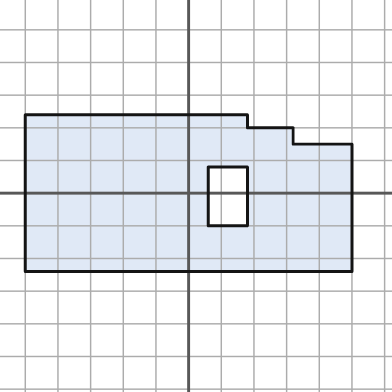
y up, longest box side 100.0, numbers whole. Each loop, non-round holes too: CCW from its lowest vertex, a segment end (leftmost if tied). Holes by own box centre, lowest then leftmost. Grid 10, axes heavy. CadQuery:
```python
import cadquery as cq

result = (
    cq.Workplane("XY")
    .moveTo(-50.0, -24.0)
    .lineTo(50.0, -24.0)
    .lineTo(50.0, 15.0)
    .lineTo(32.0, 15.0)
    .lineTo(32.0, 20.0)
    .lineTo(18.0, 20.0)
    .lineTo(18.0, 24.0)
    .lineTo(-50.0, 24.0)
    .close()
    .moveTo(6.0, -10.0)
    .lineTo(18.0, -10.0)
    .lineTo(18.0, 8.0)
    .lineTo(6.0, 8.0)
    .close()
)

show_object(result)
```